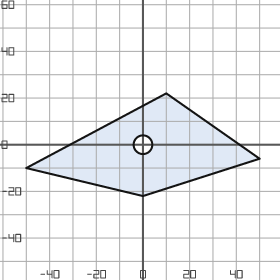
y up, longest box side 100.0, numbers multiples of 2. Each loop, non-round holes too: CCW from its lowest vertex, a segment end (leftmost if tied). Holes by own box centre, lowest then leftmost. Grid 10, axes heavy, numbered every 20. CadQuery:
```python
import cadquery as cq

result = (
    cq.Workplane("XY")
    .moveTo(0.0, -22.0)
    .lineTo(50.0, -6.0)
    .lineTo(10.0, 22.0)
    .lineTo(-50.0, -10.0)
    .close()
    .moveTo(0.0, 0.0)
    .circle(4.0)
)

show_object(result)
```